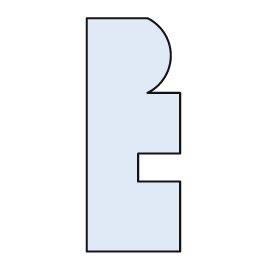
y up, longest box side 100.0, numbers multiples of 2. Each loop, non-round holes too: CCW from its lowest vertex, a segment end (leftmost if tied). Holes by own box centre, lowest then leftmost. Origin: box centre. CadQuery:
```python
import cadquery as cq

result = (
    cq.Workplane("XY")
    .moveTo(-20.0, -50.0)
    .lineTo(20.0, -50.0)
    .lineTo(20.0, -20.0)
    .lineTo(2.0, -20.0)
    .lineTo(2.0, -8.0)
    .lineTo(20.0, -8.0)
    .lineTo(20.0, 18.0)
    .lineTo(6.0, 18.0)
    .threePointArc((16.0, 34.0), (6.0, 50.0))
    .lineTo(-20.0, 50.0)
    .close()
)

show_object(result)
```